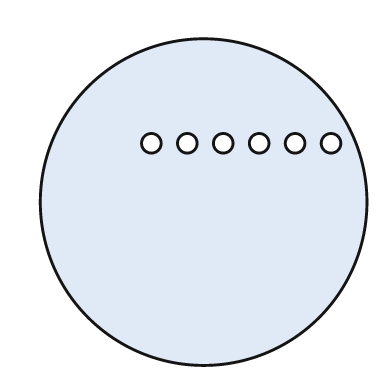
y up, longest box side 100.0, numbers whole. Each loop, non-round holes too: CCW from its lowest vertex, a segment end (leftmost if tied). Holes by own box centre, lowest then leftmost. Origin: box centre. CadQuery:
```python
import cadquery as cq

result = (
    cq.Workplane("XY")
    .moveTo(0.0, 0.0)
    .circle(50.0)
    .moveTo(-16.0, 18.0)
    .circle(3.0)
    .moveTo(-5.0, 18.0)
    .circle(3.0)
    .moveTo(6.0, 18.0)
    .circle(3.0)
    .moveTo(17.0, 18.0)
    .circle(3.0)
    .moveTo(28.0, 18.0)
    .circle(3.0)
    .moveTo(39.0, 18.0)
    .circle(3.0)
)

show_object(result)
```